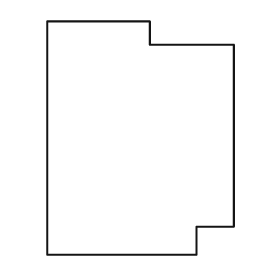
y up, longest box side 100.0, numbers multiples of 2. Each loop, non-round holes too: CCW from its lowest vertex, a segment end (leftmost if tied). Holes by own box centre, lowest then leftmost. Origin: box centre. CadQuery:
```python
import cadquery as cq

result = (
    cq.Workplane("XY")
    .moveTo(-40.0, -50.0)
    .lineTo(24.0, -50.0)
    .lineTo(24.0, -38.0)
    .lineTo(40.0, -38.0)
    .lineTo(40.0, 40.0)
    .lineTo(4.0, 40.0)
    .lineTo(4.0, 50.0)
    .lineTo(-40.0, 50.0)
    .close()
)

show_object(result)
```